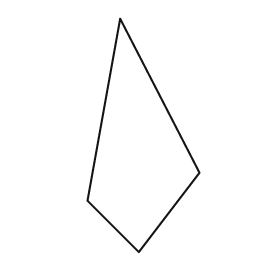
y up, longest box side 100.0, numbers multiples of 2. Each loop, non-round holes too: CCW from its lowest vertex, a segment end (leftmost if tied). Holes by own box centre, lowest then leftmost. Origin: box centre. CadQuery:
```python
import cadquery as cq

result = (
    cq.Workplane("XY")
    .moveTo(-2.0, -50.0)
    .lineTo(24.0, -16.0)
    .lineTo(-10.0, 50.0)
    .lineTo(-24.0, -28.0)
    .close()
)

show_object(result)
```